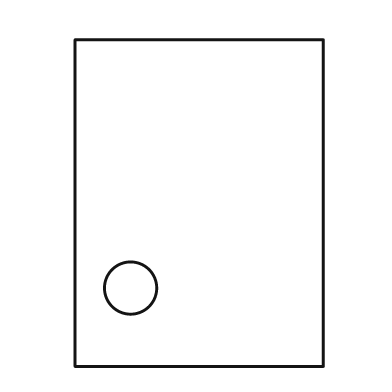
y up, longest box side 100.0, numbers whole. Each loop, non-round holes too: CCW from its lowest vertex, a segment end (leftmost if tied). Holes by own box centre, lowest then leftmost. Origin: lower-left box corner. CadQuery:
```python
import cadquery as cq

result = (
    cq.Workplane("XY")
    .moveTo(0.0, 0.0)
    .lineTo(76.0, 0.0)
    .lineTo(76.0, 100.0)
    .lineTo(0.0, 100.0)
    .close()
    .moveTo(17.0, 24.0)
    .circle(8.0)
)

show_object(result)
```